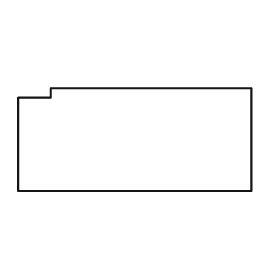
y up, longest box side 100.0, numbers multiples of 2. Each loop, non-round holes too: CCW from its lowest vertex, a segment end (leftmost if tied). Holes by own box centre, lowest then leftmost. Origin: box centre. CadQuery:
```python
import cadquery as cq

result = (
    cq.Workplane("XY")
    .moveTo(-50.0, -22.0)
    .lineTo(50.0, -22.0)
    .lineTo(50.0, 22.0)
    .lineTo(-36.0, 22.0)
    .lineTo(-36.0, 18.0)
    .lineTo(-50.0, 18.0)
    .close()
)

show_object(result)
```